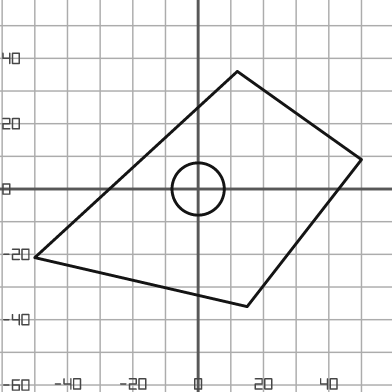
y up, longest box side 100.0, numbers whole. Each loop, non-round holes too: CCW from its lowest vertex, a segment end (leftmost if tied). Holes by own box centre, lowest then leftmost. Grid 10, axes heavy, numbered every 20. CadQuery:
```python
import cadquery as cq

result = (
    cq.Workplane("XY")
    .moveTo(15.0, -36.0)
    .lineTo(50.0, 9.0)
    .lineTo(12.0, 36.0)
    .lineTo(-50.0, -21.0)
    .close()
    .moveTo(0.0, 0.0)
    .circle(8.0)
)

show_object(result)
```